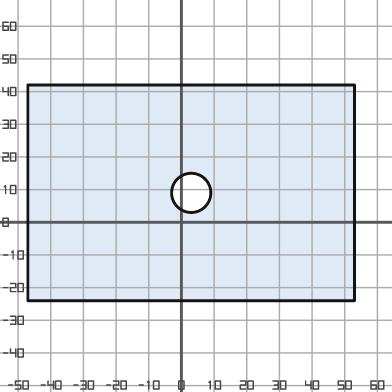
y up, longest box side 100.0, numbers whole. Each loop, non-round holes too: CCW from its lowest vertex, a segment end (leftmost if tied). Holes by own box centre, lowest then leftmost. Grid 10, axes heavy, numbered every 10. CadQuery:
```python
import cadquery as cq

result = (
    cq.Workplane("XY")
    .moveTo(-47.0, -24.0)
    .lineTo(53.0, -24.0)
    .lineTo(53.0, 42.0)
    .lineTo(-47.0, 42.0)
    .close()
    .moveTo(3.0, 9.0)
    .circle(6.0)
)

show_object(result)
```